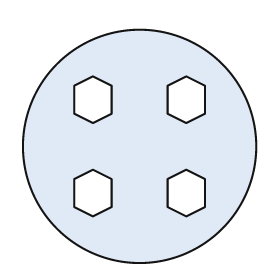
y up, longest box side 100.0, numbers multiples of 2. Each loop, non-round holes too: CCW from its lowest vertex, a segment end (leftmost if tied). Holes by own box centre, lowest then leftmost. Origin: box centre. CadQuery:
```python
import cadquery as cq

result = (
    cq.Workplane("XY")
    .moveTo(0.0, 0.0)
    .circle(50.0)
    .moveTo(-20.0, -30.0)
    .lineTo(-12.0, -26.0)
    .lineTo(-12.0, -14.0)
    .lineTo(-20.0, -10.0)
    .lineTo(-28.0, -14.0)
    .lineTo(-28.0, -26.0)
    .close()
    .moveTo(20.0, -30.0)
    .lineTo(28.0, -26.0)
    .lineTo(28.0, -14.0)
    .lineTo(20.0, -10.0)
    .lineTo(12.0, -14.0)
    .lineTo(12.0, -26.0)
    .close()
    .moveTo(-20.0, 10.0)
    .lineTo(-12.0, 14.0)
    .lineTo(-12.0, 26.0)
    .lineTo(-20.0, 30.0)
    .lineTo(-28.0, 26.0)
    .lineTo(-28.0, 14.0)
    .close()
    .moveTo(20.0, 10.0)
    .lineTo(28.0, 14.0)
    .lineTo(28.0, 26.0)
    .lineTo(20.0, 30.0)
    .lineTo(12.0, 26.0)
    .lineTo(12.0, 14.0)
    .close()
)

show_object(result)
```